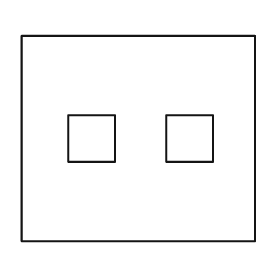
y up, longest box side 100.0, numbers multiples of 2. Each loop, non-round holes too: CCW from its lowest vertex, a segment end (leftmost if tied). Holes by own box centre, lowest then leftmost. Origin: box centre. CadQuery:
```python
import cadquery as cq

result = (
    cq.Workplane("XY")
    .moveTo(-50.0, -44.0)
    .lineTo(50.0, -44.0)
    .lineTo(50.0, 44.0)
    .lineTo(-50.0, 44.0)
    .close()
    .moveTo(-30.0, -10.0)
    .lineTo(-10.0, -10.0)
    .lineTo(-10.0, 10.0)
    .lineTo(-30.0, 10.0)
    .close()
    .moveTo(12.0, -10.0)
    .lineTo(32.0, -10.0)
    .lineTo(32.0, 10.0)
    .lineTo(12.0, 10.0)
    .close()
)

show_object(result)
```